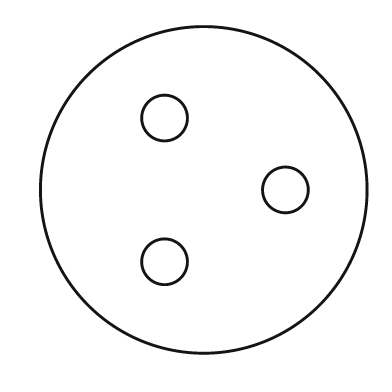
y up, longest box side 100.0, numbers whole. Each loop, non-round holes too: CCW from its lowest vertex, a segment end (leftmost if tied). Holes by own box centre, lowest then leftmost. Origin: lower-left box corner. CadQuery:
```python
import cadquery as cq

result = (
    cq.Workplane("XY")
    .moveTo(50.0, 50.0)
    .circle(50.0)
    .moveTo(38.0, 28.0)
    .circle(7.0)
    .moveTo(75.0, 50.0)
    .circle(7.0)
    .moveTo(38.0, 72.0)
    .circle(7.0)
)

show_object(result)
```